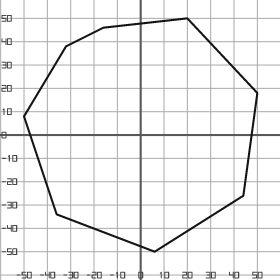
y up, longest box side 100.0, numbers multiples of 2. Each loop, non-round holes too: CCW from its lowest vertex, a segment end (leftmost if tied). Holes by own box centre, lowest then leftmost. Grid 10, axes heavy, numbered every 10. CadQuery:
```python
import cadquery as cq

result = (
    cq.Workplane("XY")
    .moveTo(6.0, -50.0)
    .lineTo(44.0, -26.0)
    .lineTo(50.0, 18.0)
    .lineTo(20.0, 50.0)
    .lineTo(-16.0, 46.0)
    .lineTo(-32.0, 38.0)
    .lineTo(-50.0, 8.0)
    .lineTo(-36.0, -34.0)
    .close()
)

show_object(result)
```